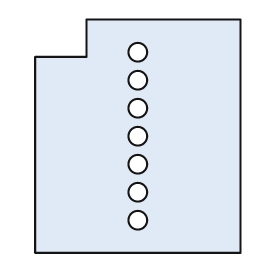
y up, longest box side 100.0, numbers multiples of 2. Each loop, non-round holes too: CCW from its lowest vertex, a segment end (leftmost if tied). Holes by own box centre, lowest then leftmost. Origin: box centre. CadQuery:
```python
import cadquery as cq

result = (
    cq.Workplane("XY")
    .moveTo(-44.0, -50.0)
    .lineTo(44.0, -50.0)
    .lineTo(44.0, 50.0)
    .lineTo(-22.0, 50.0)
    .lineTo(-22.0, 34.0)
    .lineTo(-44.0, 34.0)
    .close()
    .moveTo(0.0, -36.0)
    .circle(4.0)
    .moveTo(0.0, -24.0)
    .circle(4.0)
    .moveTo(0.0, -12.0)
    .circle(4.0)
    .moveTo(0.0, 0.0)
    .circle(4.0)
    .moveTo(0.0, 12.0)
    .circle(4.0)
    .moveTo(0.0, 24.0)
    .circle(4.0)
    .moveTo(0.0, 36.0)
    .circle(4.0)
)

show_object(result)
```